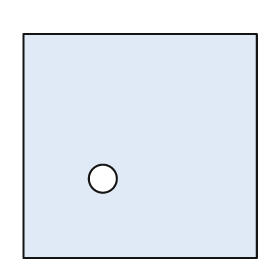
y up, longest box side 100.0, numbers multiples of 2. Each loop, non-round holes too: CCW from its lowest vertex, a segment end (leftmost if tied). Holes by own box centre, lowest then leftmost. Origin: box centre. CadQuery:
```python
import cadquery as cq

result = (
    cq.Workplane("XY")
    .moveTo(-50.0, -48.0)
    .lineTo(50.0, -48.0)
    .lineTo(50.0, 48.0)
    .lineTo(-50.0, 48.0)
    .close()
    .moveTo(-16.0, -14.0)
    .circle(6.0)
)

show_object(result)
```